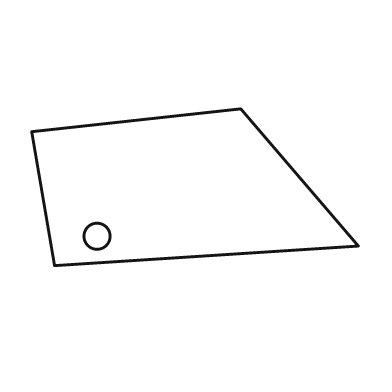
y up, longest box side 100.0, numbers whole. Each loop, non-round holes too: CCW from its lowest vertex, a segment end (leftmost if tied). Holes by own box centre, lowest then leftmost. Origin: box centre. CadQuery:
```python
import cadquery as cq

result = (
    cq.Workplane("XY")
    .moveTo(-43.0, -24.0)
    .lineTo(50.0, -18.0)
    .lineTo(14.0, 24.0)
    .lineTo(-50.0, 17.0)
    .close()
    .moveTo(-30.0, -15.0)
    .circle(4.0)
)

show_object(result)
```